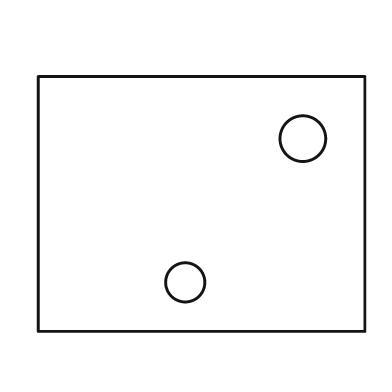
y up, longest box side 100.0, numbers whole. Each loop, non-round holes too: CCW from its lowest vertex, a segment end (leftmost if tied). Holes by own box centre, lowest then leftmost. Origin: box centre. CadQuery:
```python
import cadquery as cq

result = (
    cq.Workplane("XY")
    .moveTo(-50.0, -39.0)
    .lineTo(50.0, -39.0)
    .lineTo(50.0, 39.0)
    .lineTo(-50.0, 39.0)
    .close()
    .moveTo(-5.0, -24.0)
    .circle(6.0)
    .moveTo(31.0, 20.0)
    .circle(7.0)
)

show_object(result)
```